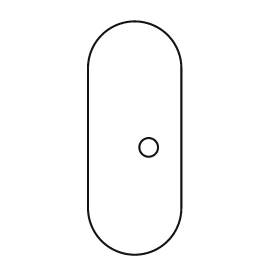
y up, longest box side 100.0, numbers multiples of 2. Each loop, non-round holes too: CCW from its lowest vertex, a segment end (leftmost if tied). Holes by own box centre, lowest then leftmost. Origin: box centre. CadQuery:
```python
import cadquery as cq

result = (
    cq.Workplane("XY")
    .moveTo(-20.0, -30.0)
    .threePointArc((0.0, -50.0), (20.0, -30.0))
    .lineTo(20.0, 30.0)
    .threePointArc((0.0, 50.0), (-20.0, 30.0))
    .close()
    .moveTo(6.0, -4.0)
    .circle(4.0)
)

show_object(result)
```